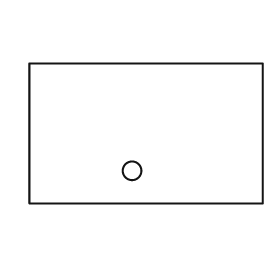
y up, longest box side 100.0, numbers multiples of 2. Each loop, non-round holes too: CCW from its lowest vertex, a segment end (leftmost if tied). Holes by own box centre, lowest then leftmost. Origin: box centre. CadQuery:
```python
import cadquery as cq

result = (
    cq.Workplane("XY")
    .moveTo(-50.0, -30.0)
    .lineTo(50.0, -30.0)
    .lineTo(50.0, 30.0)
    .lineTo(-50.0, 30.0)
    .close()
    .moveTo(-6.0, -16.0)
    .circle(4.0)
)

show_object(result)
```